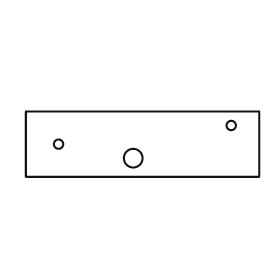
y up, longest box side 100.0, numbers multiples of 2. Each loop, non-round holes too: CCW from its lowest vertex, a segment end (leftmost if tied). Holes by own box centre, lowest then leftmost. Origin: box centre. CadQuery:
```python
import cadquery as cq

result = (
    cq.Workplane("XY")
    .moveTo(-50.0, -14.0)
    .lineTo(50.0, -14.0)
    .lineTo(50.0, 14.0)
    .lineTo(-50.0, 14.0)
    .close()
    .moveTo(-4.0, -6.0)
    .circle(4.0)
    .moveTo(-36.0, 0.0)
    .circle(2.0)
    .moveTo(38.0, 8.0)
    .circle(2.0)
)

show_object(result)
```